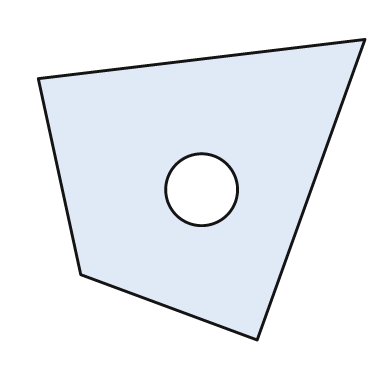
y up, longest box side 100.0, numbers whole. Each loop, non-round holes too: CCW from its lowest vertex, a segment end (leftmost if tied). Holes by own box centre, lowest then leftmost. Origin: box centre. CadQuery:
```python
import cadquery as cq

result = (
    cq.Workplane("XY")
    .moveTo(17.0, -46.0)
    .lineTo(50.0, 46.0)
    .lineTo(-50.0, 34.0)
    .lineTo(-37.0, -26.0)
    .close()
    .moveTo(0.0, 0.0)
    .circle(11.0)
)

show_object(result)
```